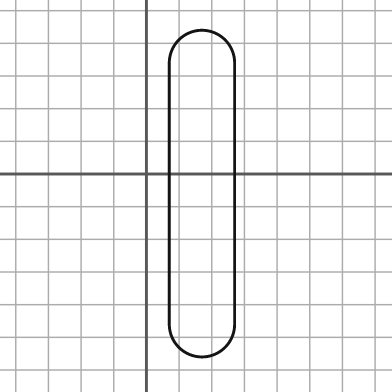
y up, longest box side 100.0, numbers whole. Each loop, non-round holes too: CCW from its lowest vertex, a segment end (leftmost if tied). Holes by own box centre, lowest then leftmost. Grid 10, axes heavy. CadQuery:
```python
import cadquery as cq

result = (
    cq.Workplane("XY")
    .moveTo(7.0, -46.0)
    .threePointArc((17.0, -56.0), (27.0, -46.0))
    .lineTo(27.0, 34.0)
    .threePointArc((17.0, 44.0), (7.0, 34.0))
    .close()
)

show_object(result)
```